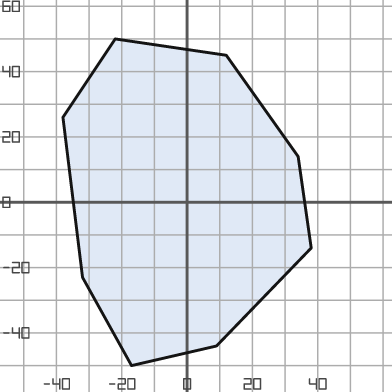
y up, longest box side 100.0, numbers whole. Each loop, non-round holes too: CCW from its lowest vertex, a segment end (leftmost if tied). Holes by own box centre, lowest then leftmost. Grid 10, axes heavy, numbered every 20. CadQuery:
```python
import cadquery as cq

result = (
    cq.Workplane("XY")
    .moveTo(-17.0, -50.0)
    .lineTo(9.0, -44.0)
    .lineTo(38.0, -14.0)
    .lineTo(34.0, 14.0)
    .lineTo(12.0, 45.0)
    .lineTo(-22.0, 50.0)
    .lineTo(-38.0, 26.0)
    .lineTo(-32.0, -23.0)
    .close()
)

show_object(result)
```